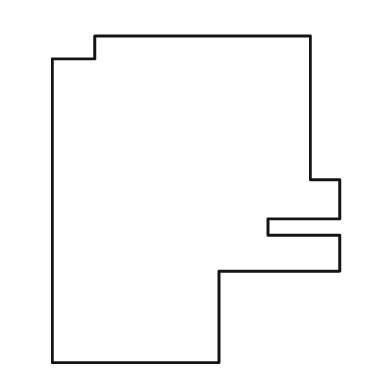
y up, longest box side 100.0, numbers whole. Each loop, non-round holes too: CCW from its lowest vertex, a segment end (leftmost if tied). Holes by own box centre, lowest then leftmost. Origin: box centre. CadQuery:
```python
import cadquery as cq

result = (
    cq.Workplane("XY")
    .moveTo(-44.0, -50.0)
    .lineTo(7.0, -50.0)
    .lineTo(7.0, -22.0)
    .lineTo(44.0, -22.0)
    .lineTo(44.0, -11.0)
    .lineTo(22.0, -11.0)
    .lineTo(22.0, -6.0)
    .lineTo(44.0, -6.0)
    .lineTo(44.0, 6.0)
    .lineTo(35.0, 6.0)
    .lineTo(35.0, 50.0)
    .lineTo(-31.0, 50.0)
    .lineTo(-31.0, 43.0)
    .lineTo(-44.0, 43.0)
    .close()
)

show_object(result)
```